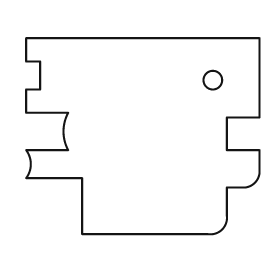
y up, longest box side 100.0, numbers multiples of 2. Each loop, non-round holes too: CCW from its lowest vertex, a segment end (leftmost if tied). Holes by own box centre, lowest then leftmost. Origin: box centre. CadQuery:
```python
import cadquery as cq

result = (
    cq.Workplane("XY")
    .moveTo(-26.0, -42.0)
    .lineTo(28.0, -42.0)
    .threePointArc((34.0, -40.0), (36.0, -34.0))
    .lineTo(36.0, -22.0)
    .lineTo(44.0, -22.0)
    .threePointArc((48.0, -20.0), (50.0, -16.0))
    .lineTo(50.0, -6.0)
    .lineTo(36.0, -6.0)
    .lineTo(36.0, 8.0)
    .lineTo(50.0, 8.0)
    .lineTo(50.0, 42.0)
    .lineTo(-50.0, 42.0)
    .lineTo(-50.0, 32.0)
    .lineTo(-44.0, 32.0)
    .lineTo(-44.0, 20.0)
    .lineTo(-50.0, 20.0)
    .lineTo(-50.0, 10.0)
    .lineTo(-32.0, 10.0)
    .threePointArc((-34.0, 2.0), (-32.0, -6.0))
    .lineTo(-50.0, -6.0)
    .threePointArc((-48.0, -12.0), (-50.0, -18.0))
    .lineTo(-26.0, -18.0)
    .close()
    .moveTo(30.0, 24.0)
    .circle(4.0)
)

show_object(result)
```